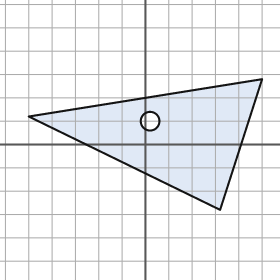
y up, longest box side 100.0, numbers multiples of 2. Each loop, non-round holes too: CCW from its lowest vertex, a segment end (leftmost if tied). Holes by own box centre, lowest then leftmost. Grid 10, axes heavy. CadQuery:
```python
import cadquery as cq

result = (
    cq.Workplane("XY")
    .moveTo(32.0, -28.0)
    .lineTo(50.0, 28.0)
    .lineTo(-50.0, 12.0)
    .close()
    .moveTo(2.0, 10.0)
    .circle(4.0)
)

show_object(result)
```